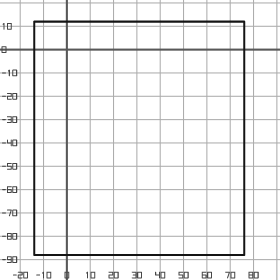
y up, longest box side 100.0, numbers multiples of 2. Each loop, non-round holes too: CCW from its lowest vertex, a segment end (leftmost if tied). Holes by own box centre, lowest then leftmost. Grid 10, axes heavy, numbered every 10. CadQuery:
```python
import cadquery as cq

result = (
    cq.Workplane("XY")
    .moveTo(-14.0, -88.0)
    .lineTo(76.0, -88.0)
    .lineTo(76.0, 12.0)
    .lineTo(-14.0, 12.0)
    .close()
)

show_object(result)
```